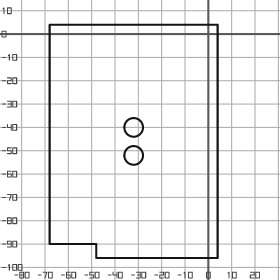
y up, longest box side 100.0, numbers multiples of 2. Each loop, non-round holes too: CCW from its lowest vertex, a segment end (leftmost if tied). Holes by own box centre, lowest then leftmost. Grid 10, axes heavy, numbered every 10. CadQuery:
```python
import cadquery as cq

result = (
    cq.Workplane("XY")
    .moveTo(-48.0, -96.0)
    .lineTo(4.0, -96.0)
    .lineTo(4.0, 4.0)
    .lineTo(-68.0, 4.0)
    .lineTo(-68.0, -90.0)
    .lineTo(-48.0, -90.0)
    .close()
    .moveTo(-32.0, -52.0)
    .circle(4.0)
    .moveTo(-32.0, -40.0)
    .circle(4.0)
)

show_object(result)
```